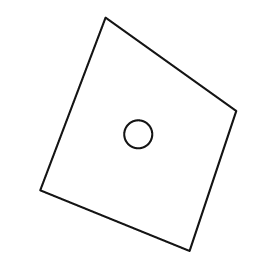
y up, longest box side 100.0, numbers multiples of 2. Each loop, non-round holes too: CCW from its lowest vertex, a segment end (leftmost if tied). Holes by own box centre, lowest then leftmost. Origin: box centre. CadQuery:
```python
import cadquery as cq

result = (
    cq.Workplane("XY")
    .moveTo(22.0, -50.0)
    .lineTo(42.0, 10.0)
    .lineTo(-14.0, 50.0)
    .lineTo(-42.0, -24.0)
    .close()
    .moveTo(0.0, 0.0)
    .circle(6.0)
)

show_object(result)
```